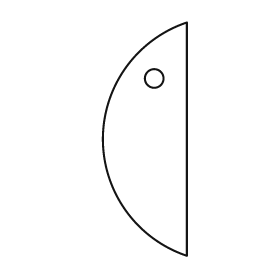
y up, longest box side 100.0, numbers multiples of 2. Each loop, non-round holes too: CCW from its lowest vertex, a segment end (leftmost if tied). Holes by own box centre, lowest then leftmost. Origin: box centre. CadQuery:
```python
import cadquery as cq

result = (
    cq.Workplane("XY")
    .moveTo(18.0, -50.0)
    .lineTo(18.0, 50.0)
    .threePointArc((-18.0, 0.0), (18.0, -50.0))
    .close()
    .moveTo(4.0, 26.0)
    .circle(4.0)
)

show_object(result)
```